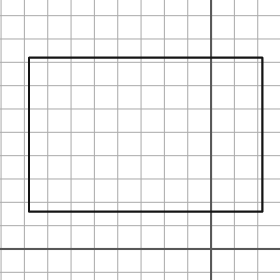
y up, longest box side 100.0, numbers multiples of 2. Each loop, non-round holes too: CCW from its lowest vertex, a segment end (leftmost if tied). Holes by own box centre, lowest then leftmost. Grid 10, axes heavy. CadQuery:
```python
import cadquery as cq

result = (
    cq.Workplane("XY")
    .moveTo(-78.0, 16.0)
    .lineTo(22.0, 16.0)
    .lineTo(22.0, 82.0)
    .lineTo(-78.0, 82.0)
    .close()
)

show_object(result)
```